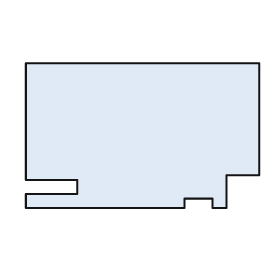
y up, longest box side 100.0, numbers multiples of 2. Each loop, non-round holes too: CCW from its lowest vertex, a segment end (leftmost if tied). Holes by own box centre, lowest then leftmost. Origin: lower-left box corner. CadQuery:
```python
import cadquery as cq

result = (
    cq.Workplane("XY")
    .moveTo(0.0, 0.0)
    .lineTo(68.0, 0.0)
    .lineTo(68.0, 4.0)
    .lineTo(80.0, 4.0)
    .lineTo(80.0, 0.0)
    .lineTo(86.0, 0.0)
    .lineTo(86.0, 14.0)
    .lineTo(100.0, 14.0)
    .lineTo(100.0, 62.0)
    .lineTo(0.0, 62.0)
    .lineTo(0.0, 12.0)
    .lineTo(22.0, 12.0)
    .lineTo(22.0, 6.0)
    .lineTo(0.0, 6.0)
    .close()
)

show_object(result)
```